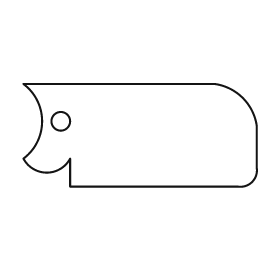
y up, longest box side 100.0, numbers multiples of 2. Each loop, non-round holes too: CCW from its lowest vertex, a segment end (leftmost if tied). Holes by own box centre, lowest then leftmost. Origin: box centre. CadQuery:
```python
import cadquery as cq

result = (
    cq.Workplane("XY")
    .moveTo(-30.0, -22.0)
    .lineTo(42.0, -22.0)
    .threePointArc((48.0, -20.0), (50.0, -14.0))
    .lineTo(50.0, 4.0)
    .threePointArc((44.0, 16.0), (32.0, 22.0))
    .lineTo(-50.0, 22.0)
    .threePointArc((-42.0, 6.0), (-50.0, -10.0))
    .threePointArc((-40.0, -16.0), (-30.0, -10.0))
    .close()
    .moveTo(-34.0, 6.0)
    .circle(4.0)
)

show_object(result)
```